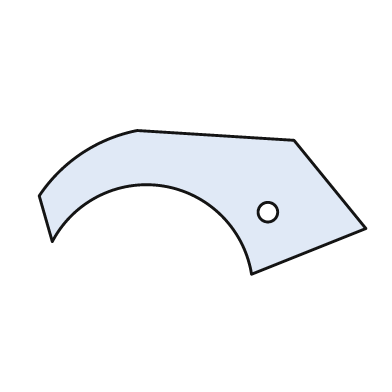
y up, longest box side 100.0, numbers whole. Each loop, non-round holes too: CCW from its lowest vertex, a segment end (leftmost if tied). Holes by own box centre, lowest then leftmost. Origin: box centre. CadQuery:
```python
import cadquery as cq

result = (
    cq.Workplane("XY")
    .moveTo(15.0, -22.0)
    .lineTo(50.0, -8.0)
    .lineTo(28.0, 19.0)
    .lineTo(-20.0, 22.0)
    .threePointArc((-37.0, 15.0), (-50.0, 2.0))
    .lineTo(-46.0, -12.0)
    .threePointArc((-12.0, 5.0), (15.0, -22.0))
    .close()
    .moveTo(20.0, -3.0)
    .circle(3.0)
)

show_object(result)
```